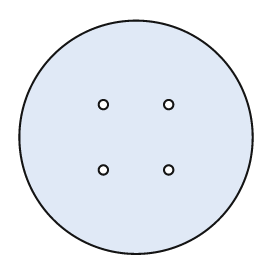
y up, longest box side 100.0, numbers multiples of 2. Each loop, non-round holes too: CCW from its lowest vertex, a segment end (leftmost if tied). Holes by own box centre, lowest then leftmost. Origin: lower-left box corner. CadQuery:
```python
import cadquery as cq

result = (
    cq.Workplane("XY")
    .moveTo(50.0, 50.0)
    .circle(50.0)
    .moveTo(36.0, 36.0)
    .circle(2.0)
    .moveTo(64.0, 36.0)
    .circle(2.0)
    .moveTo(36.0, 64.0)
    .circle(2.0)
    .moveTo(64.0, 64.0)
    .circle(2.0)
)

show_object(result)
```